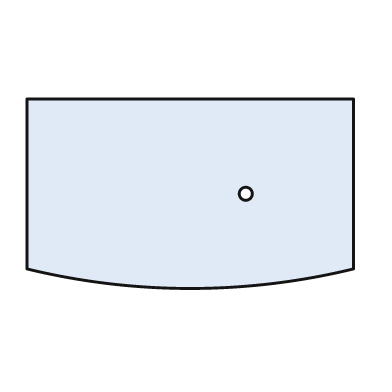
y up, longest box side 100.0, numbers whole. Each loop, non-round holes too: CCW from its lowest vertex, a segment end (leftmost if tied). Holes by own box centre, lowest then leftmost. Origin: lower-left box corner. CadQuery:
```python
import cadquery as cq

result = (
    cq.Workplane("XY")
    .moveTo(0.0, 6.0)
    .threePointArc((50.0, 0.0), (100.0, 6.0))
    .lineTo(100.0, 58.0)
    .lineTo(0.0, 58.0)
    .close()
    .moveTo(67.0, 29.0)
    .circle(2.0)
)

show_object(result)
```